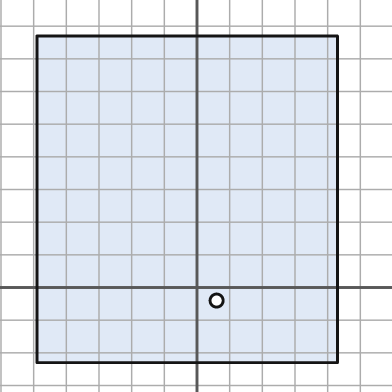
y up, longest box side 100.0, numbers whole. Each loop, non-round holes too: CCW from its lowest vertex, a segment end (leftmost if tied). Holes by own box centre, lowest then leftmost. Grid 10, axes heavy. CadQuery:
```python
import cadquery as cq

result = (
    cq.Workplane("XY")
    .moveTo(-49.0, -23.0)
    .lineTo(43.0, -23.0)
    .lineTo(43.0, 77.0)
    .lineTo(-49.0, 77.0)
    .close()
    .moveTo(6.0, -4.0)
    .circle(2.0)
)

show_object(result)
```